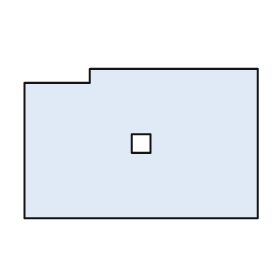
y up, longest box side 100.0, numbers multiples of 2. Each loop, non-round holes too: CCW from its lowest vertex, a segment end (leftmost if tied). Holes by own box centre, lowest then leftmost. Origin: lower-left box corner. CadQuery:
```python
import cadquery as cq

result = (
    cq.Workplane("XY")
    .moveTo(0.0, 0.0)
    .lineTo(100.0, 0.0)
    .lineTo(100.0, 64.0)
    .lineTo(28.0, 64.0)
    .lineTo(28.0, 58.0)
    .lineTo(0.0, 58.0)
    .close()
    .moveTo(46.0, 28.0)
    .lineTo(54.0, 28.0)
    .lineTo(54.0, 36.0)
    .lineTo(46.0, 36.0)
    .close()
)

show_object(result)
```